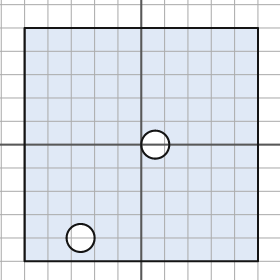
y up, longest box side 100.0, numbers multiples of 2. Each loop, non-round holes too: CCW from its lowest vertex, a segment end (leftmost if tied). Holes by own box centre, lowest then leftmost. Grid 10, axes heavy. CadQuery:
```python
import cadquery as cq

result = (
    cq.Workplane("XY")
    .moveTo(-50.0, -50.0)
    .lineTo(50.0, -50.0)
    .lineTo(50.0, 50.0)
    .lineTo(-50.0, 50.0)
    .close()
    .moveTo(-26.0, -40.0)
    .circle(6.0)
    .moveTo(6.0, 0.0)
    .circle(6.0)
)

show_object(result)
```